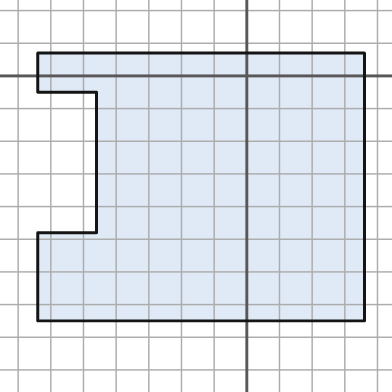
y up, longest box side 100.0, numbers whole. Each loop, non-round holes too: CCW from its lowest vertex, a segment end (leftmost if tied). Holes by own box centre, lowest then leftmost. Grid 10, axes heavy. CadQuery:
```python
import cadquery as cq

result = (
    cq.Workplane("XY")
    .moveTo(-64.0, -75.0)
    .lineTo(36.0, -75.0)
    .lineTo(36.0, 7.0)
    .lineTo(-64.0, 7.0)
    .lineTo(-64.0, -5.0)
    .lineTo(-46.0, -5.0)
    .lineTo(-46.0, -48.0)
    .lineTo(-64.0, -48.0)
    .close()
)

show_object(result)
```